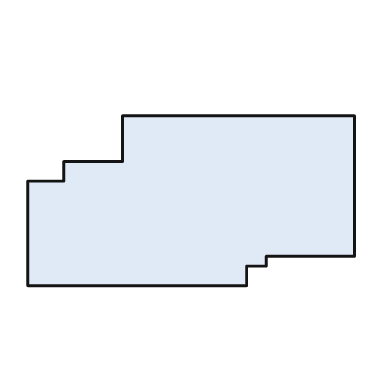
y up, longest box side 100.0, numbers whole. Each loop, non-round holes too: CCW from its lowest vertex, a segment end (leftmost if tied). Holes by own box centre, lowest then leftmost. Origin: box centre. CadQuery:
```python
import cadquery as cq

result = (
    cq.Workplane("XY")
    .moveTo(-50.0, -26.0)
    .lineTo(17.0, -26.0)
    .lineTo(17.0, -20.0)
    .lineTo(23.0, -20.0)
    .lineTo(23.0, -17.0)
    .lineTo(50.0, -17.0)
    .lineTo(50.0, 26.0)
    .lineTo(-21.0, 26.0)
    .lineTo(-21.0, 12.0)
    .lineTo(-39.0, 12.0)
    .lineTo(-39.0, 6.0)
    .lineTo(-50.0, 6.0)
    .close()
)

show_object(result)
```